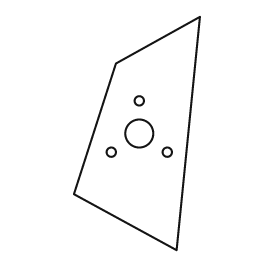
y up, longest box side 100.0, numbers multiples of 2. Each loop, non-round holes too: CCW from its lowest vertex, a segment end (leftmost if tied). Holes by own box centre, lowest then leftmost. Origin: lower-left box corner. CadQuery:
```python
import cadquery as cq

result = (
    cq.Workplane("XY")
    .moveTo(44.0, 0.0)
    .lineTo(54.0, 100.0)
    .lineTo(18.0, 80.0)
    .lineTo(0.0, 24.0)
    .close()
    .moveTo(16.0, 42.0)
    .circle(2.0)
    .moveTo(40.0, 42.0)
    .circle(2.0)
    .moveTo(28.0, 50.0)
    .circle(6.0)
    .moveTo(28.0, 64.0)
    .circle(2.0)
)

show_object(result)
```